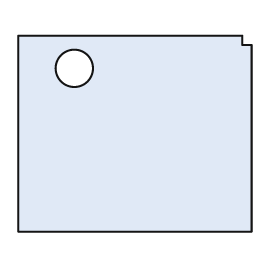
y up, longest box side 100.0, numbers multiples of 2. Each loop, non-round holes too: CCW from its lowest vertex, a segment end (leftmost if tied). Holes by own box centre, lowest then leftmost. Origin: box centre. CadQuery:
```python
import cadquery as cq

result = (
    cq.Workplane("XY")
    .moveTo(-50.0, -42.0)
    .lineTo(50.0, -42.0)
    .lineTo(50.0, 38.0)
    .lineTo(46.0, 38.0)
    .lineTo(46.0, 42.0)
    .lineTo(-50.0, 42.0)
    .close()
    .moveTo(-26.0, 28.0)
    .circle(8.0)
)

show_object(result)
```